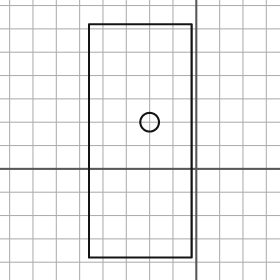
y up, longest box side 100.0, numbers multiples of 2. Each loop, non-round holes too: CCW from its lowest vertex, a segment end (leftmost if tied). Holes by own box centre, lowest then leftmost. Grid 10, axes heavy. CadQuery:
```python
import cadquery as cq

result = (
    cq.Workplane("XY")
    .moveTo(-46.0, -38.0)
    .lineTo(-2.0, -38.0)
    .lineTo(-2.0, 62.0)
    .lineTo(-46.0, 62.0)
    .close()
    .moveTo(-20.0, 20.0)
    .circle(4.0)
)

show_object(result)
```